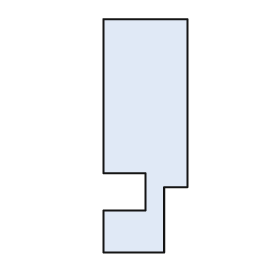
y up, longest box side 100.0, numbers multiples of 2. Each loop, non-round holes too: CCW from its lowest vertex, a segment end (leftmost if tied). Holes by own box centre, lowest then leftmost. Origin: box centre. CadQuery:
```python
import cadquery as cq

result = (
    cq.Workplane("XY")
    .moveTo(-18.0, -50.0)
    .lineTo(8.0, -50.0)
    .lineTo(8.0, -22.0)
    .lineTo(18.0, -22.0)
    .lineTo(18.0, 50.0)
    .lineTo(-18.0, 50.0)
    .lineTo(-18.0, -16.0)
    .lineTo(0.0, -16.0)
    .lineTo(0.0, -32.0)
    .lineTo(-18.0, -32.0)
    .close()
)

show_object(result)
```